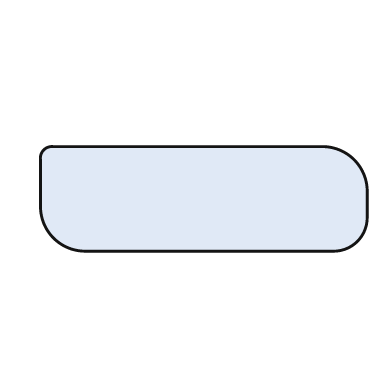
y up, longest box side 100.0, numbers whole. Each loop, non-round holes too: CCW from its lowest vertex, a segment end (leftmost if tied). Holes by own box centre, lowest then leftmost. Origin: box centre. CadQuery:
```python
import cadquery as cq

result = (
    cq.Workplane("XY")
    .moveTo(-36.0, -16.0)
    .lineTo(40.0, -16.0)
    .threePointArc((47.0, -13.0), (50.0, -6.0))
    .lineTo(50.0, 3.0)
    .threePointArc((46.0, 12.0), (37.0, 16.0))
    .lineTo(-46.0, 16.0)
    .threePointArc((-49.0, 15.0), (-50.0, 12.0))
    .lineTo(-50.0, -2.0)
    .threePointArc((-46.0, -12.0), (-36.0, -16.0))
    .close()
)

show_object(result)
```